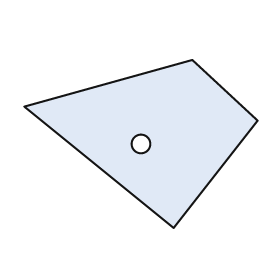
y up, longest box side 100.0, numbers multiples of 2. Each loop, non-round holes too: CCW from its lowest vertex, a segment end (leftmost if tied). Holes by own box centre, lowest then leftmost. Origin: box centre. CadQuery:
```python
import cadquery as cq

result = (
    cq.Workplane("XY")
    .moveTo(14.0, -36.0)
    .lineTo(50.0, 10.0)
    .lineTo(22.0, 36.0)
    .lineTo(-50.0, 16.0)
    .close()
    .moveTo(0.0, 0.0)
    .circle(4.0)
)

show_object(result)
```